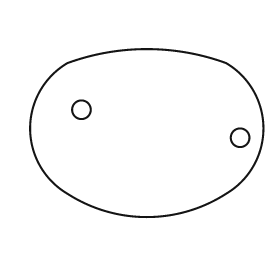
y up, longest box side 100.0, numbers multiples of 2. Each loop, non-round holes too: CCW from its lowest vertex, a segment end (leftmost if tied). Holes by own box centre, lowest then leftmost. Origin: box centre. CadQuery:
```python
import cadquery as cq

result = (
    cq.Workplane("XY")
    .moveTo(-34.0, -26.0)
    .threePointArc((0.0, -36.0), (34.0, -26.0))
    .threePointArc((50.0, 2.0), (34.0, 30.0))
    .threePointArc((0.0, 36.0), (-34.0, 30.0))
    .threePointArc((-50.0, 2.0), (-34.0, -26.0))
    .close()
    .moveTo(40.0, -2.0)
    .circle(4.0)
    .moveTo(-28.0, 10.0)
    .circle(4.0)
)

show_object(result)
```